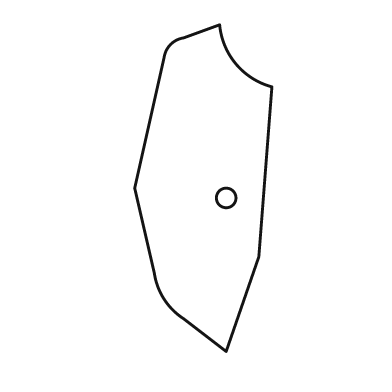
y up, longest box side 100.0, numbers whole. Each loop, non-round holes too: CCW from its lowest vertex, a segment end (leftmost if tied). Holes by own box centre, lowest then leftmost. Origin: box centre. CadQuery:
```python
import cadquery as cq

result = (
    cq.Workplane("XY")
    .moveTo(7.0, -50.0)
    .lineTo(17.0, -21.0)
    .lineTo(21.0, 31.0)
    .threePointArc((10.0, 38.0), (5.0, 50.0))
    .lineTo(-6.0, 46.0)
    .threePointArc((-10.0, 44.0), (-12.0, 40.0))
    .lineTo(-21.0, 0.0)
    .lineTo(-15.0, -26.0)
    .threePointArc((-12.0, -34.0), (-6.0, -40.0))
    .close()
    .moveTo(7.0, -3.0)
    .circle(3.0)
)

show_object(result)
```